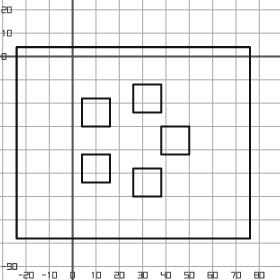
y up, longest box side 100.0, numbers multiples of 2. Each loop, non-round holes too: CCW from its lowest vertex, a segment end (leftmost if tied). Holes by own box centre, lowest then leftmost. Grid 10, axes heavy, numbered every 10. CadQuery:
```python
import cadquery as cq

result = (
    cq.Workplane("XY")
    .moveTo(-24.0, -78.0)
    .lineTo(76.0, -78.0)
    .lineTo(76.0, 4.0)
    .lineTo(-24.0, 4.0)
    .close()
    .moveTo(26.0, -60.0)
    .lineTo(38.0, -60.0)
    .lineTo(38.0, -48.0)
    .lineTo(26.0, -48.0)
    .close()
    .moveTo(4.0, -54.0)
    .lineTo(16.0, -54.0)
    .lineTo(16.0, -42.0)
    .lineTo(4.0, -42.0)
    .close()
    .moveTo(38.0, -42.0)
    .lineTo(50.0, -42.0)
    .lineTo(50.0, -30.0)
    .lineTo(38.0, -30.0)
    .close()
    .moveTo(4.0, -30.0)
    .lineTo(16.0, -30.0)
    .lineTo(16.0, -18.0)
    .lineTo(4.0, -18.0)
    .close()
    .moveTo(26.0, -24.0)
    .lineTo(38.0, -24.0)
    .lineTo(38.0, -12.0)
    .lineTo(26.0, -12.0)
    .close()
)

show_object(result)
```